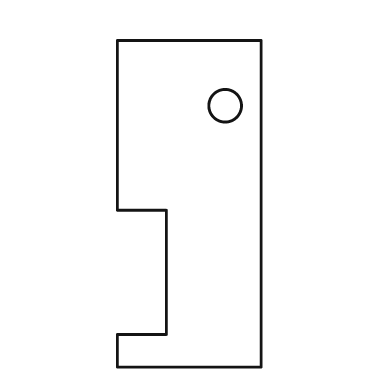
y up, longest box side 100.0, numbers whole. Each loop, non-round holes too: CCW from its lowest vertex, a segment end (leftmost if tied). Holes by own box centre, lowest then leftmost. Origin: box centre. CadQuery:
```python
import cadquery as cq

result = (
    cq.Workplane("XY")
    .moveTo(-22.0, -50.0)
    .lineTo(22.0, -50.0)
    .lineTo(22.0, 50.0)
    .lineTo(-22.0, 50.0)
    .lineTo(-22.0, -2.0)
    .lineTo(-7.0, -2.0)
    .lineTo(-7.0, -40.0)
    .lineTo(-22.0, -40.0)
    .close()
    .moveTo(11.0, 30.0)
    .circle(5.0)
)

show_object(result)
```